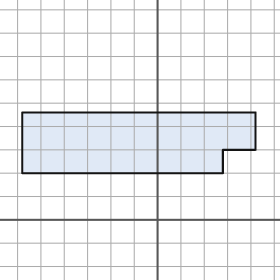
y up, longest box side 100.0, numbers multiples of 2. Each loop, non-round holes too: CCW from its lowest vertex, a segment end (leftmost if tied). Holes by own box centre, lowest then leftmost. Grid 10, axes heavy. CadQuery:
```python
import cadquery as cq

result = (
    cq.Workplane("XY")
    .moveTo(-58.0, 20.0)
    .lineTo(28.0, 20.0)
    .lineTo(28.0, 30.0)
    .lineTo(42.0, 30.0)
    .lineTo(42.0, 46.0)
    .lineTo(-58.0, 46.0)
    .close()
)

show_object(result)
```